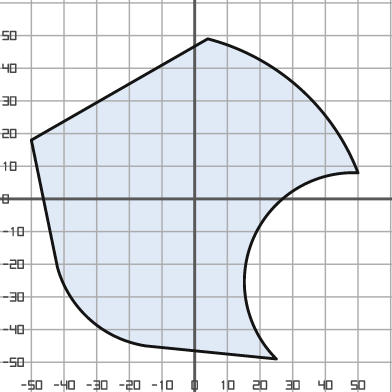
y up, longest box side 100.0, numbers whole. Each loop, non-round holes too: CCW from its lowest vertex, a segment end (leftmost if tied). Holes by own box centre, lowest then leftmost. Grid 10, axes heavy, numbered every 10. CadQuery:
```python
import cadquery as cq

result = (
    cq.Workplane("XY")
    .moveTo(25.0, -49.0)
    .threePointArc((18.0, -12.0), (50.0, 8.0))
    .threePointArc((32.0, 34.0), (4.0, 49.0))
    .lineTo(-50.0, 18.0)
    .lineTo(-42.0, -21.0)
    .threePointArc((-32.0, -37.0), (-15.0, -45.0))
    .close()
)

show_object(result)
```